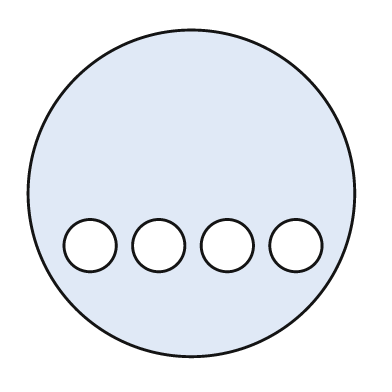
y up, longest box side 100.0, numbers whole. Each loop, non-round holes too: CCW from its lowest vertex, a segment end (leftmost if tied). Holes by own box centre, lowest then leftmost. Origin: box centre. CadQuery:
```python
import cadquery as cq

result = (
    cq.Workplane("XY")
    .moveTo(0.0, 0.0)
    .circle(50.0)
    .moveTo(-31.0, -16.0)
    .circle(8.0)
    .moveTo(-10.0, -16.0)
    .circle(8.0)
    .moveTo(11.0, -16.0)
    .circle(8.0)
    .moveTo(32.0, -16.0)
    .circle(8.0)
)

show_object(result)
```